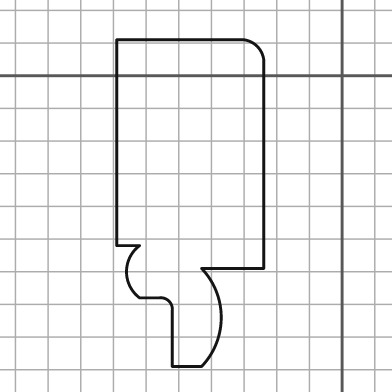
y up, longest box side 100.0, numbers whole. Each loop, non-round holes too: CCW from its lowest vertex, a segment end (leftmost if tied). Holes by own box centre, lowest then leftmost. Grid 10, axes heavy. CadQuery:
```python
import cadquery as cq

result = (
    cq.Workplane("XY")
    .moveTo(-52.0, -89.0)
    .lineTo(-43.0, -89.0)
    .threePointArc((-37.0, -74.0), (-43.0, -59.0))
    .lineTo(-24.0, -59.0)
    .lineTo(-24.0, 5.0)
    .threePointArc((-26.0, 9.0), (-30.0, 11.0))
    .lineTo(-69.0, 11.0)
    .lineTo(-69.0, -52.0)
    .lineTo(-62.0, -52.0)
    .threePointArc((-66.0, -60.0), (-62.0, -68.0))
    .lineTo(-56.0, -68.0)
    .threePointArc((-53.0, -69.0), (-52.0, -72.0))
    .close()
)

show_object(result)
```